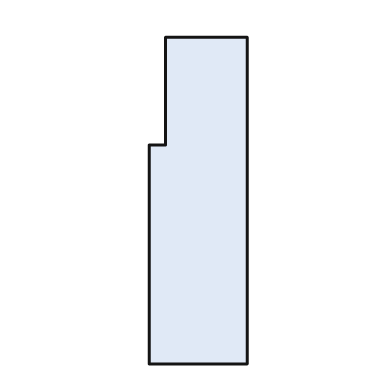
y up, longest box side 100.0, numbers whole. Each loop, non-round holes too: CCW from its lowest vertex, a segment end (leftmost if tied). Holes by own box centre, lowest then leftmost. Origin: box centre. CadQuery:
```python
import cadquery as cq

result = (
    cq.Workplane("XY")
    .moveTo(-15.0, -50.0)
    .lineTo(15.0, -50.0)
    .lineTo(15.0, 50.0)
    .lineTo(-10.0, 50.0)
    .lineTo(-10.0, 17.0)
    .lineTo(-15.0, 17.0)
    .close()
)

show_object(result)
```